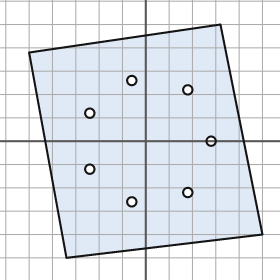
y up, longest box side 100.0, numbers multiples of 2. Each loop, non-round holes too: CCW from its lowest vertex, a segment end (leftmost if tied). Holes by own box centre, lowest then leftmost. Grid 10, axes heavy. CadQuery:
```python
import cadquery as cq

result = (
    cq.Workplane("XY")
    .moveTo(-34.0, -50.0)
    .lineTo(50.0, -40.0)
    .lineTo(32.0, 50.0)
    .lineTo(-50.0, 38.0)
    .close()
    .moveTo(-6.0, -26.0)
    .circle(2.0)
    .moveTo(18.0, -22.0)
    .circle(2.0)
    .moveTo(-24.0, -12.0)
    .circle(2.0)
    .moveTo(28.0, 0.0)
    .circle(2.0)
    .moveTo(-24.0, 12.0)
    .circle(2.0)
    .moveTo(18.0, 22.0)
    .circle(2.0)
    .moveTo(-6.0, 26.0)
    .circle(2.0)
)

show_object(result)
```